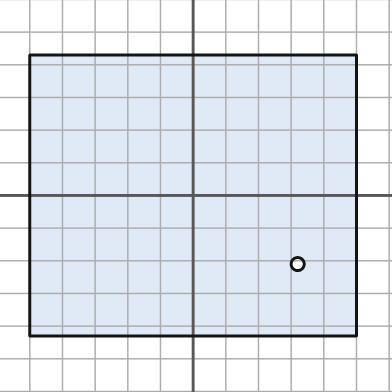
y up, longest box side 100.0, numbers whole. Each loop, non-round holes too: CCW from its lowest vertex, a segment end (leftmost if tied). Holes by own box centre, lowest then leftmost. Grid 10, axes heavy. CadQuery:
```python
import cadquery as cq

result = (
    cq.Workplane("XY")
    .moveTo(-50.0, -43.0)
    .lineTo(50.0, -43.0)
    .lineTo(50.0, 43.0)
    .lineTo(-50.0, 43.0)
    .close()
    .moveTo(32.0, -21.0)
    .circle(2.0)
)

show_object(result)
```